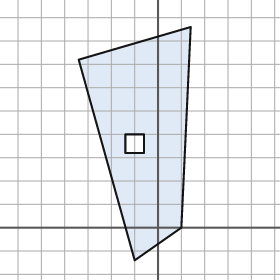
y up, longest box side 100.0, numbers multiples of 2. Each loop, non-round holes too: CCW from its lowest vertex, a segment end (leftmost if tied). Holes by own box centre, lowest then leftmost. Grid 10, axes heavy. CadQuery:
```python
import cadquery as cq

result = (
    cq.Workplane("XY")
    .moveTo(-10.0, -14.0)
    .lineTo(10.0, 0.0)
    .lineTo(14.0, 86.0)
    .lineTo(-34.0, 72.0)
    .close()
    .moveTo(-14.0, 32.0)
    .lineTo(-6.0, 32.0)
    .lineTo(-6.0, 40.0)
    .lineTo(-14.0, 40.0)
    .close()
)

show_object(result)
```